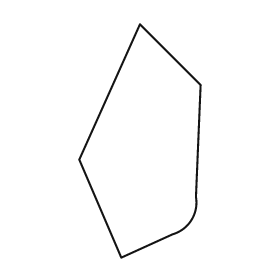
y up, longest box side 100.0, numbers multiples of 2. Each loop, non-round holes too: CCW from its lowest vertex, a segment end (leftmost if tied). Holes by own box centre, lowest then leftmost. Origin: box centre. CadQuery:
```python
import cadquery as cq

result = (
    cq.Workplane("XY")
    .moveTo(-8.0, -50.0)
    .lineTo(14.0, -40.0)
    .threePointArc((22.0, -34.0), (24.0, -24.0))
    .lineTo(26.0, 24.0)
    .lineTo(0.0, 50.0)
    .lineTo(-26.0, -8.0)
    .close()
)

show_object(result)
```